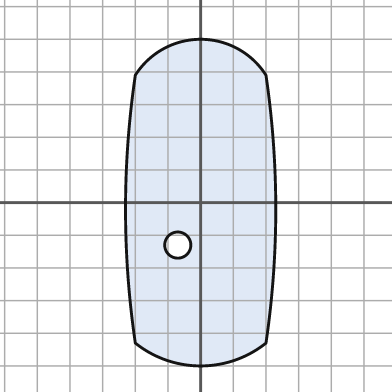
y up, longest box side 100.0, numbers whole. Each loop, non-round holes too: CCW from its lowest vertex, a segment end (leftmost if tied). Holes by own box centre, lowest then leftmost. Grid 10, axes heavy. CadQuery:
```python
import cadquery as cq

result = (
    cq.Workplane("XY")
    .moveTo(-20.0, -43.0)
    .threePointArc((0.0, -50.0), (20.0, -43.0))
    .threePointArc((23.0, -2.0), (20.0, 39.0))
    .threePointArc((0.0, 50.0), (-20.0, 39.0))
    .threePointArc((-23.0, -2.0), (-20.0, -43.0))
    .close()
    .moveTo(-7.0, -13.0)
    .circle(4.0)
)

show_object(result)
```